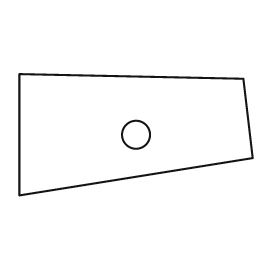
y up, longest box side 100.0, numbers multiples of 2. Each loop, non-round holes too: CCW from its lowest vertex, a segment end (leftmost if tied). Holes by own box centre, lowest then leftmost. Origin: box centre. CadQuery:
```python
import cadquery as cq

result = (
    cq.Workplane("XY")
    .moveTo(-50.0, -26.0)
    .lineTo(50.0, -10.0)
    .lineTo(46.0, 24.0)
    .lineTo(-50.0, 26.0)
    .close()
    .moveTo(0.0, 0.0)
    .circle(6.0)
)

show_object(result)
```